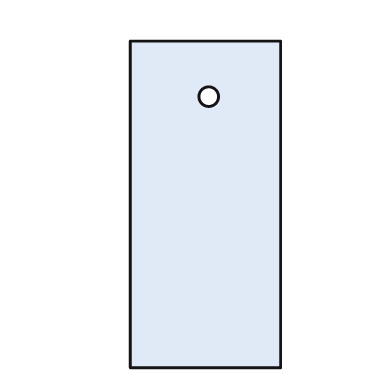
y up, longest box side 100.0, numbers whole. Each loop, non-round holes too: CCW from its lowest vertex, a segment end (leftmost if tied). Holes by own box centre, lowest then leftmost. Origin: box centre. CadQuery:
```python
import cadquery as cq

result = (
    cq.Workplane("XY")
    .moveTo(-23.0, -50.0)
    .lineTo(23.0, -50.0)
    .lineTo(23.0, 50.0)
    .lineTo(-23.0, 50.0)
    .close()
    .moveTo(1.0, 33.0)
    .circle(3.0)
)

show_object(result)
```